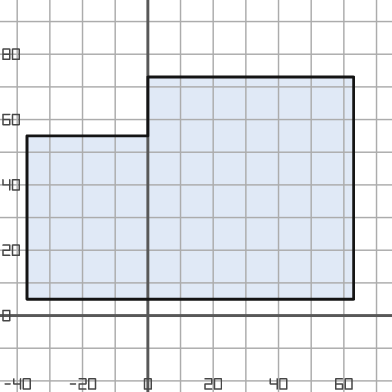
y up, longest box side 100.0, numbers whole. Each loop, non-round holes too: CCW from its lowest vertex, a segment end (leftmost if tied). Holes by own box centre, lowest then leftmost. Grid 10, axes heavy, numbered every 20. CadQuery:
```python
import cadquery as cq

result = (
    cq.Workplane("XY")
    .moveTo(-37.0, 5.0)
    .lineTo(63.0, 5.0)
    .lineTo(63.0, 73.0)
    .lineTo(0.0, 73.0)
    .lineTo(0.0, 55.0)
    .lineTo(-37.0, 55.0)
    .close()
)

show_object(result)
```